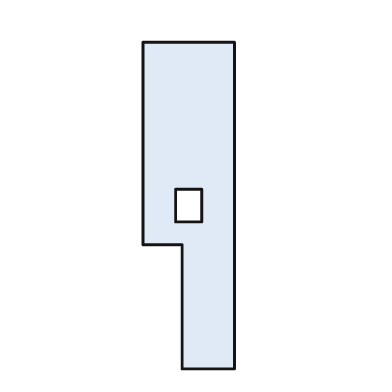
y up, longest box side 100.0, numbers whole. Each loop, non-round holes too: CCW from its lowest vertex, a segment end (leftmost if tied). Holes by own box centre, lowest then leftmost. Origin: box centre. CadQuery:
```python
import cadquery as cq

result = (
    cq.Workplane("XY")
    .moveTo(-2.0, -50.0)
    .lineTo(14.0, -50.0)
    .lineTo(14.0, 50.0)
    .lineTo(-14.0, 50.0)
    .lineTo(-14.0, -12.0)
    .lineTo(-2.0, -12.0)
    .close()
    .moveTo(-4.0, -5.0)
    .lineTo(4.0, -5.0)
    .lineTo(4.0, 5.0)
    .lineTo(-4.0, 5.0)
    .close()
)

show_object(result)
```